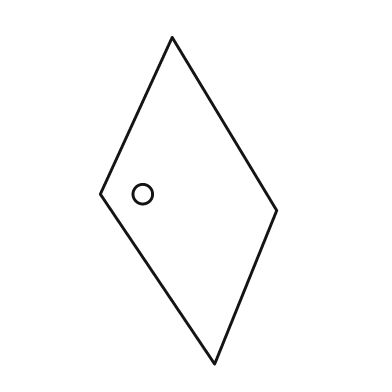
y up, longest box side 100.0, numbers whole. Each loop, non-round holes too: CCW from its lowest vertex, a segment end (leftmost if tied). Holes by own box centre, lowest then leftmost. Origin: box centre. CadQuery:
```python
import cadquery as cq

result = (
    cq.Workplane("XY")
    .moveTo(8.0, -50.0)
    .lineTo(27.0, -3.0)
    .lineTo(-5.0, 50.0)
    .lineTo(-27.0, 2.0)
    .close()
    .moveTo(-14.0, 2.0)
    .circle(3.0)
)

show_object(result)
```